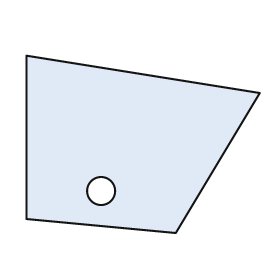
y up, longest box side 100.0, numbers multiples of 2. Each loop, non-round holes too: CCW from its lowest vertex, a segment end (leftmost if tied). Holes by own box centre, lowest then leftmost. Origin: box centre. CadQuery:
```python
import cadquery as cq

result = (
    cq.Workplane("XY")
    .moveTo(14.0, -38.0)
    .lineTo(50.0, 22.0)
    .lineTo(-50.0, 38.0)
    .lineTo(-50.0, -32.0)
    .close()
    .moveTo(-18.0, -20.0)
    .circle(6.0)
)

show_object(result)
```